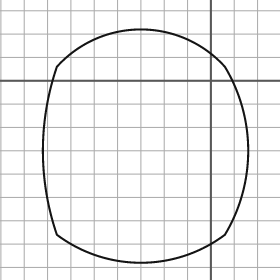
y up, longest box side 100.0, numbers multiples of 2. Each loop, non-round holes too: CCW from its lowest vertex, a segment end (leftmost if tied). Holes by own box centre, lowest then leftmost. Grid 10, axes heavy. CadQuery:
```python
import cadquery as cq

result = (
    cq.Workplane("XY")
    .moveTo(-66.0, -66.0)
    .threePointArc((-30.0, -78.0), (6.0, -66.0))
    .threePointArc((16.0, -30.0), (6.0, 6.0))
    .threePointArc((-30.0, 22.0), (-66.0, 6.0))
    .threePointArc((-72.0, -30.0), (-66.0, -66.0))
    .close()
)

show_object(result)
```